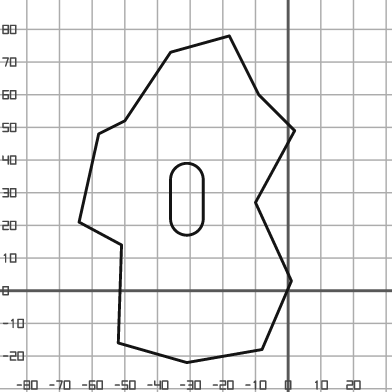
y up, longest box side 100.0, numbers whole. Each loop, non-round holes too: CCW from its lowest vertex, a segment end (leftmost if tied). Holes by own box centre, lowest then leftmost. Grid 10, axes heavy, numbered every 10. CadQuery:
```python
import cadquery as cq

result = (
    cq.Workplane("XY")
    .moveTo(-31.0, -22.0)
    .lineTo(-8.0, -18.0)
    .lineTo(1.0, 3.0)
    .lineTo(-10.0, 27.0)
    .lineTo(2.0, 49.0)
    .lineTo(-9.0, 60.0)
    .lineTo(-18.0, 78.0)
    .lineTo(-36.0, 73.0)
    .lineTo(-50.0, 52.0)
    .lineTo(-58.0, 48.0)
    .lineTo(-64.0, 21.0)
    .lineTo(-51.0, 14.0)
    .lineTo(-52.0, -16.0)
    .close()
    .moveTo(-36.0, 22.0)
    .threePointArc((-31.0, 17.0), (-26.0, 22.0))
    .lineTo(-26.0, 34.0)
    .threePointArc((-31.0, 39.0), (-36.0, 34.0))
    .close()
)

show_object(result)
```